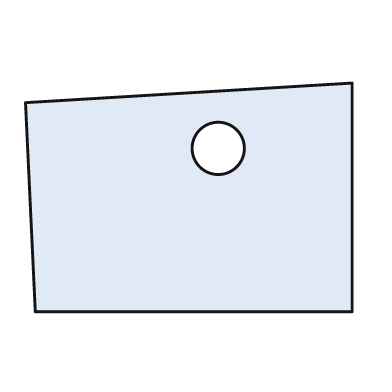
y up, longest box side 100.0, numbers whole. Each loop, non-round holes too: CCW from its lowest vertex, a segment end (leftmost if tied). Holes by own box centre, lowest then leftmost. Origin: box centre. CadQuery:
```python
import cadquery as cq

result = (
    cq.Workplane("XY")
    .moveTo(-47.0, -35.0)
    .lineTo(50.0, -35.0)
    .lineTo(50.0, 35.0)
    .lineTo(-50.0, 29.0)
    .close()
    .moveTo(9.0, 15.0)
    .circle(8.0)
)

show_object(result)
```